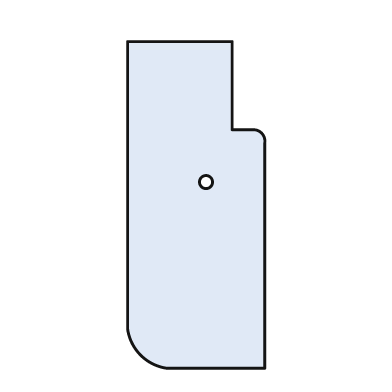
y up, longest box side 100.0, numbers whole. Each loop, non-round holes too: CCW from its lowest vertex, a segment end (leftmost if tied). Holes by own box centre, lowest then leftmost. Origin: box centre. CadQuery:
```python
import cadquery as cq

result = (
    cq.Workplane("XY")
    .moveTo(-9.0, -50.0)
    .lineTo(21.0, -50.0)
    .lineTo(21.0, 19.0)
    .threePointArc((20.0, 22.0), (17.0, 23.0))
    .lineTo(11.0, 23.0)
    .lineTo(11.0, 50.0)
    .lineTo(-21.0, 50.0)
    .lineTo(-21.0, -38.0)
    .threePointArc((-17.0, -46.0), (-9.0, -50.0))
    .close()
    .moveTo(3.0, 7.0)
    .circle(2.0)
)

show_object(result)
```